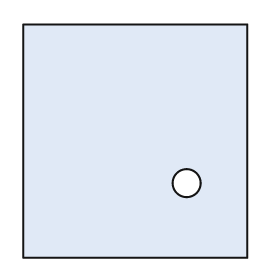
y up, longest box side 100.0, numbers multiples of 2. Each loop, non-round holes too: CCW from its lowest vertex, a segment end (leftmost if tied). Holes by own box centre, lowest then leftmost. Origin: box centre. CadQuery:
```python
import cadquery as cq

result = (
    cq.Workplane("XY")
    .moveTo(-48.0, -50.0)
    .lineTo(48.0, -50.0)
    .lineTo(48.0, 50.0)
    .lineTo(-48.0, 50.0)
    .close()
    .moveTo(22.0, -18.0)
    .circle(6.0)
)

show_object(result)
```